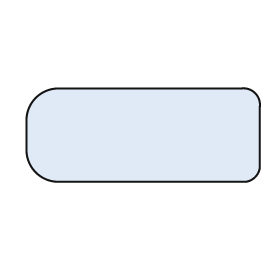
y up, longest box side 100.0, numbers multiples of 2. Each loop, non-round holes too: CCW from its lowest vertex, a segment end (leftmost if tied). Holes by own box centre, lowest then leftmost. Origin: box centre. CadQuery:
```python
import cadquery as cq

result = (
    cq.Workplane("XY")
    .moveTo(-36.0, -20.0)
    .lineTo(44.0, -20.0)
    .threePointArc((48.0, -18.0), (50.0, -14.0))
    .lineTo(50.0, 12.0)
    .threePointArc((48.0, 18.0), (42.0, 20.0))
    .lineTo(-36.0, 20.0)
    .threePointArc((-46.0, 16.0), (-50.0, 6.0))
    .lineTo(-50.0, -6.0)
    .threePointArc((-46.0, -16.0), (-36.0, -20.0))
    .close()
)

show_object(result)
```